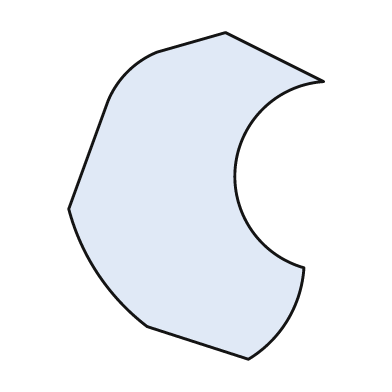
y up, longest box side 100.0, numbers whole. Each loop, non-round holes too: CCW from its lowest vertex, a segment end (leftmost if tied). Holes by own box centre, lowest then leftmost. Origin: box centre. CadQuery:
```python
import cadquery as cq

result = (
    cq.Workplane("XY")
    .moveTo(16.0, -50.0)
    .threePointArc((28.0, -38.0), (33.0, -22.0))
    .threePointArc((12.0, 9.0), (39.0, 35.0))
    .lineTo(9.0, 50.0)
    .lineTo(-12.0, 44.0)
    .threePointArc((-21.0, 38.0), (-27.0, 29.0))
    .lineTo(-39.0, -4.0)
    .threePointArc((-30.0, -24.0), (-15.0, -40.0))
    .close()
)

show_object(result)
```